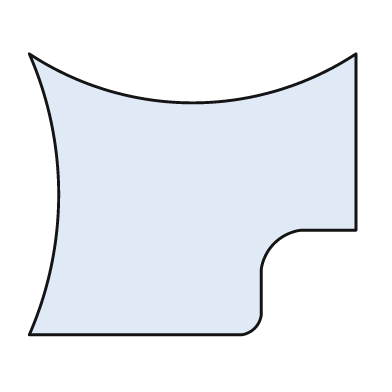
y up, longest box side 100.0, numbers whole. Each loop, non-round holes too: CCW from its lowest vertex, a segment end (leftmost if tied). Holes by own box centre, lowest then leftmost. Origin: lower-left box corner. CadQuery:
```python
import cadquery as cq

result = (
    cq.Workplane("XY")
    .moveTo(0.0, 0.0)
    .lineTo(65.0, 0.0)
    .threePointArc((69.0, 2.0), (71.0, 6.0))
    .lineTo(71.0, 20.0)
    .threePointArc((75.0, 28.0), (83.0, 32.0))
    .lineTo(100.0, 32.0)
    .lineTo(100.0, 86.0)
    .threePointArc((50.0, 71.0), (0.0, 86.0))
    .threePointArc((9.0, 43.0), (0.0, 0.0))
    .close()
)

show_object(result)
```